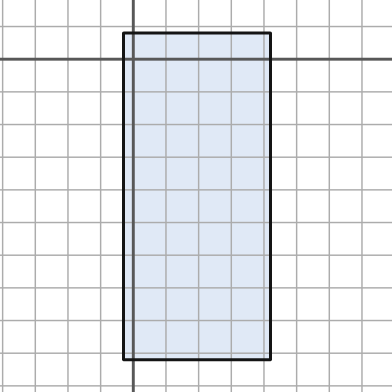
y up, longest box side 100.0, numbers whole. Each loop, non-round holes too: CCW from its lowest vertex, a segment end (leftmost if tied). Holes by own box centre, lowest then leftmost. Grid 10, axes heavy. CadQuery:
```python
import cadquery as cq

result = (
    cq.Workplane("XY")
    .moveTo(-3.0, -92.0)
    .lineTo(42.0, -92.0)
    .lineTo(42.0, 8.0)
    .lineTo(-3.0, 8.0)
    .close()
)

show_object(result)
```